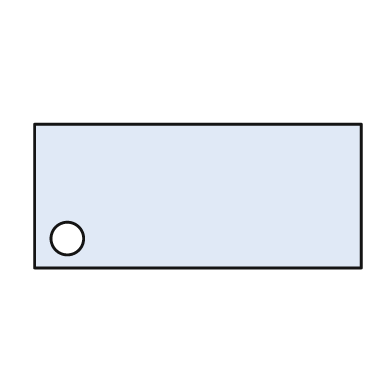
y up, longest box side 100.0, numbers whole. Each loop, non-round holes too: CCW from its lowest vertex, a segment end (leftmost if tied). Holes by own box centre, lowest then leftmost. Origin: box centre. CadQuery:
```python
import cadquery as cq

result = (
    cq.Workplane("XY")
    .moveTo(-50.0, -22.0)
    .lineTo(50.0, -22.0)
    .lineTo(50.0, 22.0)
    .lineTo(-50.0, 22.0)
    .close()
    .moveTo(-40.0, -13.0)
    .circle(5.0)
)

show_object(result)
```